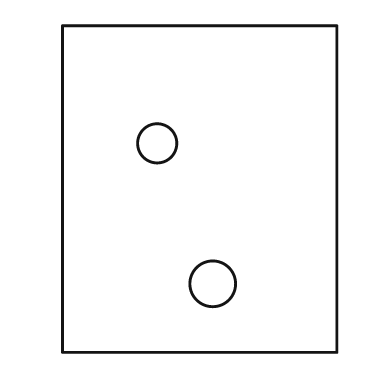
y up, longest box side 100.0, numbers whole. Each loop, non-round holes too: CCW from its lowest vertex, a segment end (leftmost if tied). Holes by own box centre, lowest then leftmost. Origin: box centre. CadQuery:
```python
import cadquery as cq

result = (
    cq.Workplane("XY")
    .moveTo(-42.0, -50.0)
    .lineTo(42.0, -50.0)
    .lineTo(42.0, 50.0)
    .lineTo(-42.0, 50.0)
    .close()
    .moveTo(4.0, -29.0)
    .circle(7.0)
    .moveTo(-13.0, 14.0)
    .circle(6.0)
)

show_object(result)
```